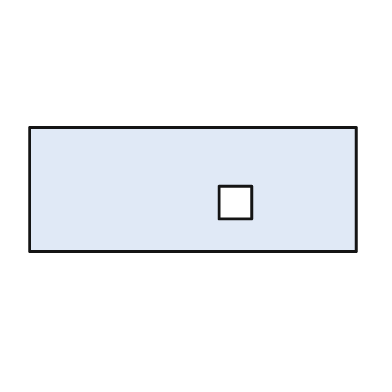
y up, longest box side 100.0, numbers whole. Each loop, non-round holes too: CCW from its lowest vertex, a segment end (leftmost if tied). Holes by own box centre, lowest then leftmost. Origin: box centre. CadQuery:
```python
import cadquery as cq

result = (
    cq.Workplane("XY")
    .moveTo(-50.0, -19.0)
    .lineTo(50.0, -19.0)
    .lineTo(50.0, 19.0)
    .lineTo(-50.0, 19.0)
    .close()
    .moveTo(8.0, -9.0)
    .lineTo(18.0, -9.0)
    .lineTo(18.0, 1.0)
    .lineTo(8.0, 1.0)
    .close()
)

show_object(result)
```